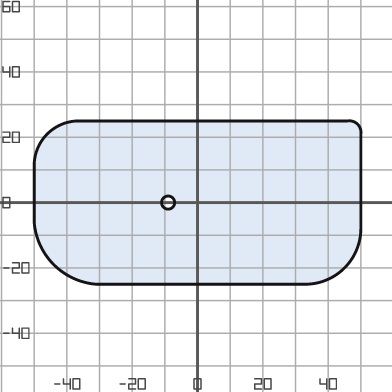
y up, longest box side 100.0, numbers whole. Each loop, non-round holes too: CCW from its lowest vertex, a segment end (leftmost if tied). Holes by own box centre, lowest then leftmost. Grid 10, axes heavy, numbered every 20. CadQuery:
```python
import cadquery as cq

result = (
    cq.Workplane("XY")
    .moveTo(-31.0, -25.0)
    .lineTo(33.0, -25.0)
    .threePointArc((45.0, -20.0), (50.0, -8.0))
    .lineTo(50.0, 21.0)
    .threePointArc((49.0, 24.0), (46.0, 25.0))
    .lineTo(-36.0, 25.0)
    .threePointArc((-46.0, 21.0), (-50.0, 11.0))
    .lineTo(-50.0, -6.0)
    .threePointArc((-44.0, -19.0), (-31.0, -25.0))
    .close()
    .moveTo(-9.0, 0.0)
    .circle(2.0)
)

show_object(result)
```